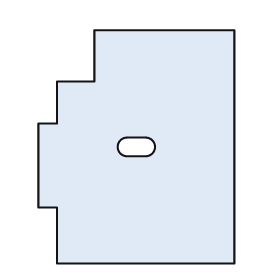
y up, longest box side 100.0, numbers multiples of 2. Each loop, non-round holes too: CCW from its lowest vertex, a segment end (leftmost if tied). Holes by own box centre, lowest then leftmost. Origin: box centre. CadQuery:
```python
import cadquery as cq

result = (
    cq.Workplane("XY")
    .moveTo(-34.0, -50.0)
    .lineTo(42.0, -50.0)
    .lineTo(42.0, 50.0)
    .lineTo(-18.0, 50.0)
    .lineTo(-18.0, 28.0)
    .lineTo(-34.0, 28.0)
    .lineTo(-34.0, 10.0)
    .lineTo(-42.0, 10.0)
    .lineTo(-42.0, -26.0)
    .lineTo(-34.0, -26.0)
    .close()
    .moveTo(-4.0, -4.0)
    .lineTo(4.0, -4.0)
    .threePointArc((8.0, 0.0), (4.0, 4.0))
    .lineTo(-4.0, 4.0)
    .threePointArc((-8.0, 0.0), (-4.0, -4.0))
    .close()
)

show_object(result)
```